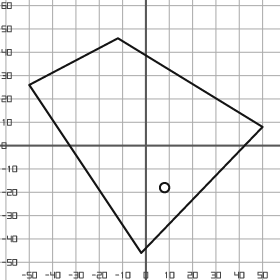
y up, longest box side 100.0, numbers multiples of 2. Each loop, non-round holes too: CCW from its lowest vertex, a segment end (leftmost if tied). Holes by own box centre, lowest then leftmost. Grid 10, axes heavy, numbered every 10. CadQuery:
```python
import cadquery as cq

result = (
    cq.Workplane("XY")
    .moveTo(-2.0, -46.0)
    .lineTo(50.0, 8.0)
    .lineTo(-12.0, 46.0)
    .lineTo(-50.0, 26.0)
    .close()
    .moveTo(8.0, -18.0)
    .circle(2.0)
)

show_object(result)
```